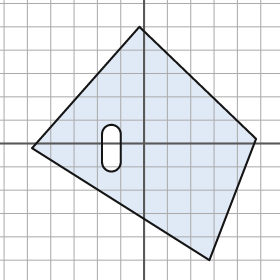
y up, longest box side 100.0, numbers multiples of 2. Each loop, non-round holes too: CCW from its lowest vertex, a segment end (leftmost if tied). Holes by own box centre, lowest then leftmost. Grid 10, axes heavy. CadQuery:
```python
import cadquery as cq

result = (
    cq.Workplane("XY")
    .moveTo(28.0, -50.0)
    .lineTo(48.0, 2.0)
    .lineTo(-2.0, 50.0)
    .lineTo(-48.0, -2.0)
    .close()
    .moveTo(-18.0, -8.0)
    .threePointArc((-14.0, -12.0), (-10.0, -8.0))
    .lineTo(-10.0, 4.0)
    .threePointArc((-14.0, 8.0), (-18.0, 4.0))
    .close()
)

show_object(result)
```